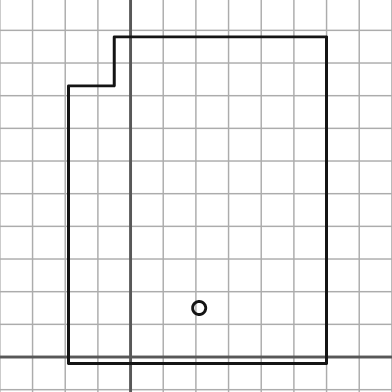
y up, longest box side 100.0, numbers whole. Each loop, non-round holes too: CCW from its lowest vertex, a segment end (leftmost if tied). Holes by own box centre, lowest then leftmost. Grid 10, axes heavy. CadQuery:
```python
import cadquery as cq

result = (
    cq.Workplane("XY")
    .moveTo(-19.0, -2.0)
    .lineTo(60.0, -2.0)
    .lineTo(60.0, 98.0)
    .lineTo(-5.0, 98.0)
    .lineTo(-5.0, 83.0)
    .lineTo(-19.0, 83.0)
    .close()
    .moveTo(21.0, 15.0)
    .circle(2.0)
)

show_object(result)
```